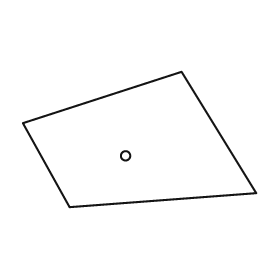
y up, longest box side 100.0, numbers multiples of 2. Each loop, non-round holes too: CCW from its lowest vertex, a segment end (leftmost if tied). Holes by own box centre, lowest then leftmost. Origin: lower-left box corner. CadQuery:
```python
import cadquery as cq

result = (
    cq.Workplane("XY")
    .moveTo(20.0, 0.0)
    .lineTo(100.0, 6.0)
    .lineTo(68.0, 58.0)
    .lineTo(0.0, 36.0)
    .close()
    .moveTo(44.0, 22.0)
    .circle(2.0)
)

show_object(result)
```